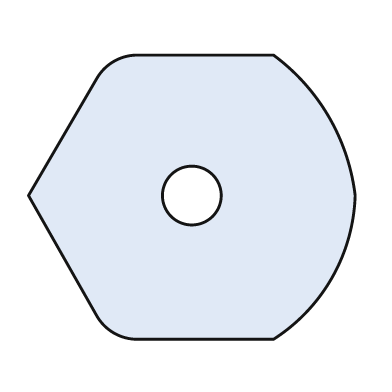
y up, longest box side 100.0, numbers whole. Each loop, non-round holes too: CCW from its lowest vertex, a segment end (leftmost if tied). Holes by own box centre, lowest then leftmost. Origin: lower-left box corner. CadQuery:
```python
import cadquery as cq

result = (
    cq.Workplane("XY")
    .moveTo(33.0, 0.0)
    .lineTo(75.0, 0.0)
    .threePointArc((93.0, 19.0), (100.0, 44.0))
    .threePointArc((92.0, 68.0), (75.0, 87.0))
    .lineTo(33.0, 87.0)
    .threePointArc((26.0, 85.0), (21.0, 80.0))
    .lineTo(0.0, 44.0)
    .lineTo(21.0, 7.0)
    .threePointArc((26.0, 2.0), (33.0, 0.0))
    .close()
    .moveTo(50.0, 44.0)
    .circle(9.0)
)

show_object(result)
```